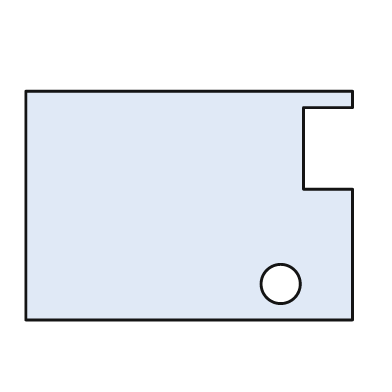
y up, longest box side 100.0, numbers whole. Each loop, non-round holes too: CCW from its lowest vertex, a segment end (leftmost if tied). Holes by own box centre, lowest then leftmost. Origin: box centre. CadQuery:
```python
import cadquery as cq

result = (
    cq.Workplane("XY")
    .moveTo(-50.0, -35.0)
    .lineTo(50.0, -35.0)
    .lineTo(50.0, 5.0)
    .lineTo(35.0, 5.0)
    .lineTo(35.0, 30.0)
    .lineTo(50.0, 30.0)
    .lineTo(50.0, 35.0)
    .lineTo(-50.0, 35.0)
    .close()
    .moveTo(28.0, -24.0)
    .circle(6.0)
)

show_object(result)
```